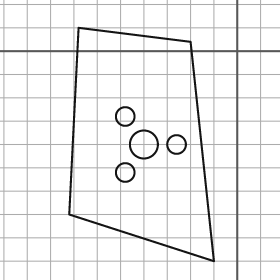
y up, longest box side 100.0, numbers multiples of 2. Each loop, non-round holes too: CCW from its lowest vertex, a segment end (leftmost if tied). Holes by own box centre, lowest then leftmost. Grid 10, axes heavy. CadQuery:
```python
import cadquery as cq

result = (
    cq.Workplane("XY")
    .moveTo(-10.0, -90.0)
    .lineTo(-20.0, 4.0)
    .lineTo(-68.0, 10.0)
    .lineTo(-72.0, -70.0)
    .close()
    .moveTo(-48.0, -52.0)
    .circle(4.0)
    .moveTo(-40.0, -40.0)
    .circle(6.0)
    .moveTo(-26.0, -40.0)
    .circle(4.0)
    .moveTo(-48.0, -28.0)
    .circle(4.0)
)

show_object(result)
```